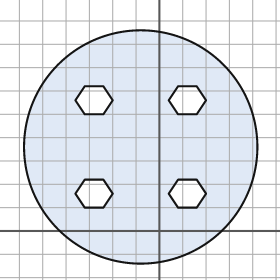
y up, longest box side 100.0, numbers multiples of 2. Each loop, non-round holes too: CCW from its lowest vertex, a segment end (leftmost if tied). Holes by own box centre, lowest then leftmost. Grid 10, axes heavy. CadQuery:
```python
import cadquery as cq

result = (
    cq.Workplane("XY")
    .moveTo(-8.0, 36.0)
    .circle(50.0)
    .moveTo(-32.0, 10.0)
    .lineTo(-24.0, 10.0)
    .lineTo(-20.0, 16.0)
    .lineTo(-24.0, 22.0)
    .lineTo(-32.0, 22.0)
    .lineTo(-36.0, 16.0)
    .close()
    .moveTo(8.0, 10.0)
    .lineTo(16.0, 10.0)
    .lineTo(20.0, 16.0)
    .lineTo(16.0, 22.0)
    .lineTo(8.0, 22.0)
    .lineTo(4.0, 16.0)
    .close()
    .moveTo(-32.0, 50.0)
    .lineTo(-24.0, 50.0)
    .lineTo(-20.0, 56.0)
    .lineTo(-24.0, 62.0)
    .lineTo(-32.0, 62.0)
    .lineTo(-36.0, 56.0)
    .close()
    .moveTo(8.0, 50.0)
    .lineTo(16.0, 50.0)
    .lineTo(20.0, 56.0)
    .lineTo(16.0, 62.0)
    .lineTo(8.0, 62.0)
    .lineTo(4.0, 56.0)
    .close()
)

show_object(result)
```